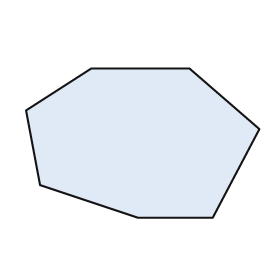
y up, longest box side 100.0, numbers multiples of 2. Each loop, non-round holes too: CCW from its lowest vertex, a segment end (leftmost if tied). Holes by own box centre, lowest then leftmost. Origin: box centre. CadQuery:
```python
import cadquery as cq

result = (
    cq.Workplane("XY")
    .moveTo(-2.0, -32.0)
    .lineTo(30.0, -32.0)
    .lineTo(50.0, 6.0)
    .lineTo(20.0, 32.0)
    .lineTo(-22.0, 32.0)
    .lineTo(-50.0, 14.0)
    .lineTo(-44.0, -18.0)
    .close()
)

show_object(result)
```